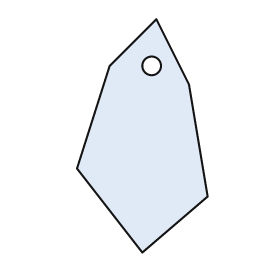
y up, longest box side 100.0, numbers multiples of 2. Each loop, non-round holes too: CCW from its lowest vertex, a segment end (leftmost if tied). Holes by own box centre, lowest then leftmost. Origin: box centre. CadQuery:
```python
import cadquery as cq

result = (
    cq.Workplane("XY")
    .moveTo(0.0, -50.0)
    .lineTo(28.0, -26.0)
    .lineTo(20.0, 22.0)
    .lineTo(6.0, 50.0)
    .lineTo(-14.0, 30.0)
    .lineTo(-28.0, -14.0)
    .close()
    .moveTo(4.0, 30.0)
    .circle(4.0)
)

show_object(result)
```